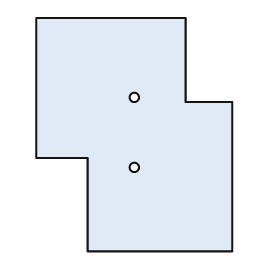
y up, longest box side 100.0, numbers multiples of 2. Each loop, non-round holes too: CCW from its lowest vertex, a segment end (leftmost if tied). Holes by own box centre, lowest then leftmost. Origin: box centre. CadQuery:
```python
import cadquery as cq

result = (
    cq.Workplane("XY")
    .moveTo(-20.0, -50.0)
    .lineTo(42.0, -50.0)
    .lineTo(42.0, 14.0)
    .lineTo(22.0, 14.0)
    .lineTo(22.0, 50.0)
    .lineTo(-42.0, 50.0)
    .lineTo(-42.0, -10.0)
    .lineTo(-20.0, -10.0)
    .close()
    .moveTo(0.0, -14.0)
    .circle(2.0)
    .moveTo(0.0, 16.0)
    .circle(2.0)
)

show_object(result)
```